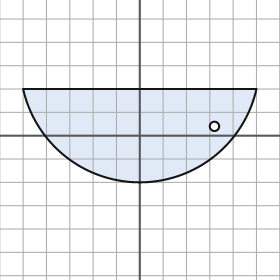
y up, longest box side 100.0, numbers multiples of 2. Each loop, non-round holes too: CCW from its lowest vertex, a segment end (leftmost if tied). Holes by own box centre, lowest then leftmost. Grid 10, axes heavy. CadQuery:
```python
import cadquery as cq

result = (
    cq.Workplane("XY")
    .moveTo(-50.0, 20.0)
    .threePointArc((0.0, -20.0), (50.0, 20.0))
    .close()
    .moveTo(32.0, 4.0)
    .circle(2.0)
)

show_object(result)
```